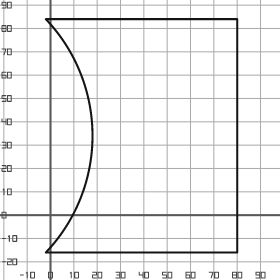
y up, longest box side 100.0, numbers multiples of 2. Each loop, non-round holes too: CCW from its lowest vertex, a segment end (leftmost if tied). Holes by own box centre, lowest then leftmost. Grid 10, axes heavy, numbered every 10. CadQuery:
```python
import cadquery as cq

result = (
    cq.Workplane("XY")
    .moveTo(-2.0, -16.0)
    .lineTo(80.0, -16.0)
    .lineTo(80.0, 84.0)
    .lineTo(-2.0, 84.0)
    .threePointArc((18.0, 34.0), (-2.0, -16.0))
    .close()
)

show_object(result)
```